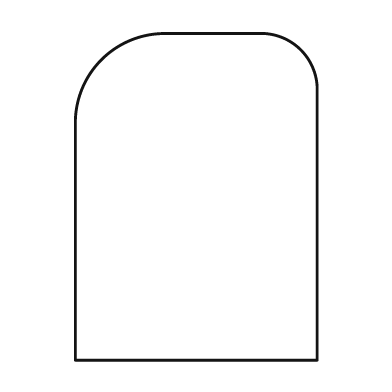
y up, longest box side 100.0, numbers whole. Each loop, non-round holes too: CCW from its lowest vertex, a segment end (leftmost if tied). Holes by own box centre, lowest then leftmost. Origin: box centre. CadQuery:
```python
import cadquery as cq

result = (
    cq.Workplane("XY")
    .moveTo(-37.0, -50.0)
    .lineTo(37.0, -50.0)
    .lineTo(37.0, 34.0)
    .threePointArc((32.0, 45.0), (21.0, 50.0))
    .lineTo(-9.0, 50.0)
    .threePointArc((-29.0, 42.0), (-37.0, 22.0))
    .close()
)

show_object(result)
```